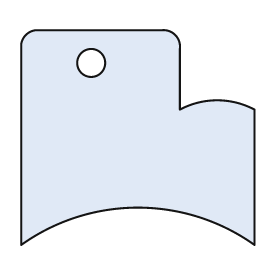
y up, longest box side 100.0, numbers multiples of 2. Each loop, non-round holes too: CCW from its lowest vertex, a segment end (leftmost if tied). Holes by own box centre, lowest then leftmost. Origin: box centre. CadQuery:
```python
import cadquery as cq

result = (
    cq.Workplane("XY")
    .moveTo(-50.0, -46.0)
    .threePointArc((0.0, -30.0), (50.0, -46.0))
    .lineTo(50.0, 12.0)
    .threePointArc((34.0, 16.0), (18.0, 12.0))
    .lineTo(18.0, 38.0)
    .threePointArc((16.0, 44.0), (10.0, 46.0))
    .lineTo(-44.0, 46.0)
    .threePointArc((-48.0, 44.0), (-50.0, 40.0))
    .close()
    .moveTo(-20.0, 32.0)
    .circle(6.0)
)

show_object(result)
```